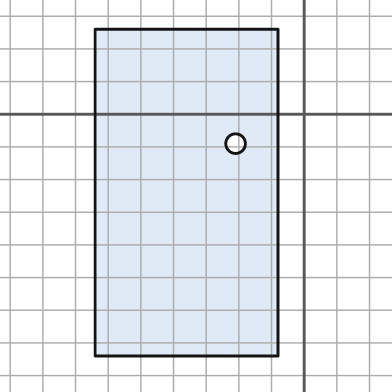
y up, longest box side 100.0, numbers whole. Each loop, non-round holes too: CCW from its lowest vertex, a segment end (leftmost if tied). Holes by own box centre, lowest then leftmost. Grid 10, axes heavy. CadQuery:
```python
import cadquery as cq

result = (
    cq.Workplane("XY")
    .moveTo(-64.0, -74.0)
    .lineTo(-8.0, -74.0)
    .lineTo(-8.0, 26.0)
    .lineTo(-64.0, 26.0)
    .close()
    .moveTo(-21.0, -9.0)
    .circle(3.0)
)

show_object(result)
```